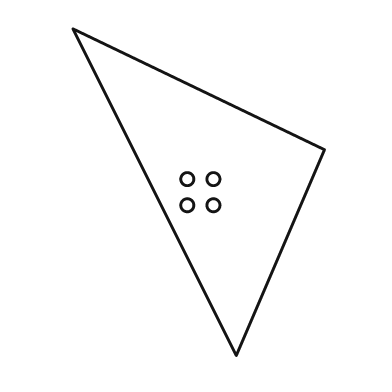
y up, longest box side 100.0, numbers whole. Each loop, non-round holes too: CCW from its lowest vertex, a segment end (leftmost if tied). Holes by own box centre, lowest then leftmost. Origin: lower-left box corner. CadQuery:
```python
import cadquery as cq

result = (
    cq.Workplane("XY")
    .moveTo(50.0, 0.0)
    .lineTo(77.0, 63.0)
    .lineTo(0.0, 100.0)
    .close()
    .moveTo(35.0, 46.0)
    .circle(2.0)
    .moveTo(43.0, 46.0)
    .circle(2.0)
    .moveTo(35.0, 54.0)
    .circle(2.0)
    .moveTo(43.0, 54.0)
    .circle(2.0)
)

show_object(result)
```